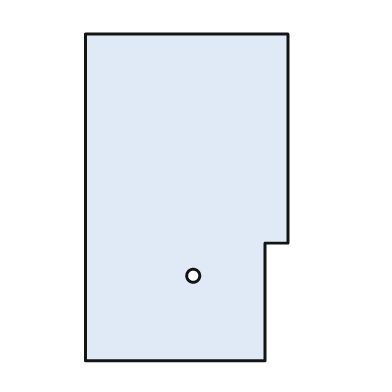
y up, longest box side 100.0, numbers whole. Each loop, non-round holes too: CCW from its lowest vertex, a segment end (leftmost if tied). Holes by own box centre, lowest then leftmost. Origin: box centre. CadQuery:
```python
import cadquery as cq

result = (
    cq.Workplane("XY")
    .moveTo(-31.0, -50.0)
    .lineTo(24.0, -50.0)
    .lineTo(24.0, -14.0)
    .lineTo(31.0, -14.0)
    .lineTo(31.0, 50.0)
    .lineTo(-31.0, 50.0)
    .close()
    .moveTo(2.0, -24.0)
    .circle(2.0)
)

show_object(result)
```